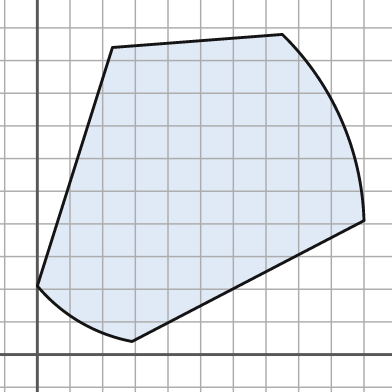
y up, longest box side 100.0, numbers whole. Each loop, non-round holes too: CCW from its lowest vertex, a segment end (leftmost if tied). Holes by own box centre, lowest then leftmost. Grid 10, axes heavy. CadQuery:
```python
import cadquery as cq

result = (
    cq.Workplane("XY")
    .moveTo(29.0, 4.0)
    .lineTo(100.0, 41.0)
    .threePointArc((93.0, 72.0), (75.0, 98.0))
    .lineTo(23.0, 94.0)
    .lineTo(0.0, 21.0)
    .threePointArc((13.0, 10.0), (29.0, 4.0))
    .close()
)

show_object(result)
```